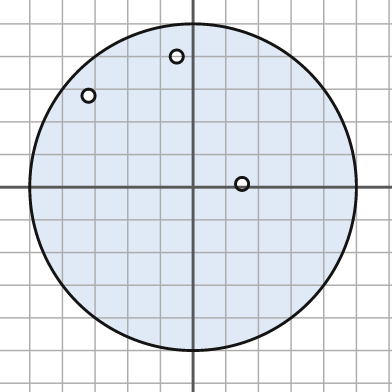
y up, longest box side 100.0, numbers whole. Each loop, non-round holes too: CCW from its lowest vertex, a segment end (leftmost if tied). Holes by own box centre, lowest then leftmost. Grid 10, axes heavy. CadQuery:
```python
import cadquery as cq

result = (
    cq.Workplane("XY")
    .moveTo(0.0, 0.0)
    .circle(50.0)
    .moveTo(15.0, 1.0)
    .circle(2.0)
    .moveTo(-32.0, 28.0)
    .circle(2.0)
    .moveTo(-5.0, 40.0)
    .circle(2.0)
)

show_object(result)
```